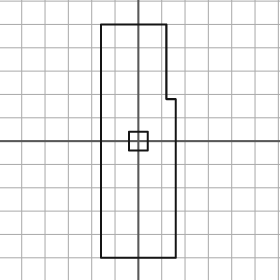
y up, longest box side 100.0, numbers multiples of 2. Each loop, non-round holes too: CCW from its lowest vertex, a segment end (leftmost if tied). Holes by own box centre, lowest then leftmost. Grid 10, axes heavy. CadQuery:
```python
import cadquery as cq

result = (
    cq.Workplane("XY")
    .moveTo(-16.0, -50.0)
    .lineTo(16.0, -50.0)
    .lineTo(16.0, 18.0)
    .lineTo(12.0, 18.0)
    .lineTo(12.0, 50.0)
    .lineTo(-16.0, 50.0)
    .close()
    .moveTo(-4.0, -4.0)
    .lineTo(4.0, -4.0)
    .lineTo(4.0, 4.0)
    .lineTo(-4.0, 4.0)
    .close()
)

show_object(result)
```